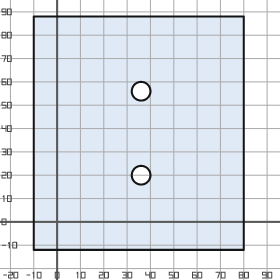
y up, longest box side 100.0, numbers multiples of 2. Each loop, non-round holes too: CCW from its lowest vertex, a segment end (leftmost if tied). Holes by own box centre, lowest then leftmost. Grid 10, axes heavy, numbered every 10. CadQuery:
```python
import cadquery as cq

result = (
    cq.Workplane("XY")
    .moveTo(-10.0, -12.0)
    .lineTo(80.0, -12.0)
    .lineTo(80.0, 88.0)
    .lineTo(-10.0, 88.0)
    .close()
    .moveTo(36.0, 20.0)
    .circle(4.0)
    .moveTo(36.0, 56.0)
    .circle(4.0)
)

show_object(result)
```